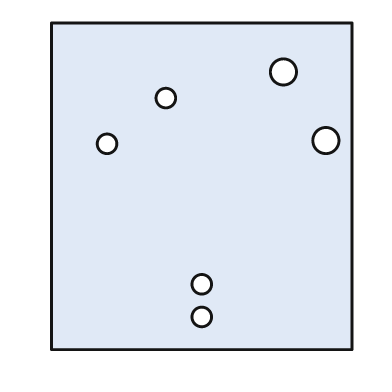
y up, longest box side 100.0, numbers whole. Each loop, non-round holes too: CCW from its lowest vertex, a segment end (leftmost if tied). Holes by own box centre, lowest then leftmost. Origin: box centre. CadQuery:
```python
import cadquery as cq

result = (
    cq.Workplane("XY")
    .moveTo(-46.0, -50.0)
    .lineTo(46.0, -50.0)
    .lineTo(46.0, 50.0)
    .lineTo(-46.0, 50.0)
    .close()
    .moveTo(0.0, -40.0)
    .circle(3.0)
    .moveTo(0.0, -30.0)
    .circle(3.0)
    .moveTo(-29.0, 13.0)
    .circle(3.0)
    .moveTo(38.0, 14.0)
    .circle(4.0)
    .moveTo(-11.0, 27.0)
    .circle(3.0)
    .moveTo(25.0, 35.0)
    .circle(4.0)
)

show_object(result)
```